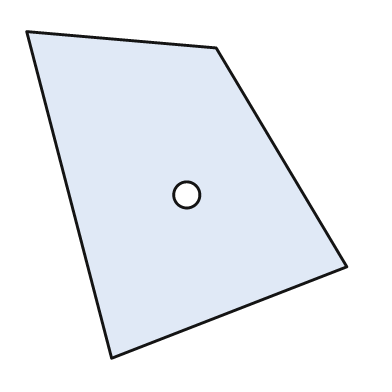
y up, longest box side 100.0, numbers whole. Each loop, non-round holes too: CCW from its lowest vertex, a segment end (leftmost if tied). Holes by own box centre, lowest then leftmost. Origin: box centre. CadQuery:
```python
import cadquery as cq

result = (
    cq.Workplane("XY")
    .moveTo(-23.0, -50.0)
    .lineTo(49.0, -22.0)
    .lineTo(9.0, 45.0)
    .lineTo(-49.0, 50.0)
    .close()
    .moveTo(0.0, 0.0)
    .circle(4.0)
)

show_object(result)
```